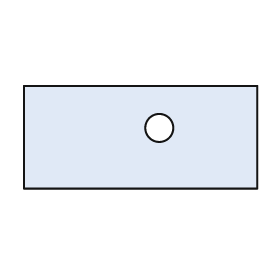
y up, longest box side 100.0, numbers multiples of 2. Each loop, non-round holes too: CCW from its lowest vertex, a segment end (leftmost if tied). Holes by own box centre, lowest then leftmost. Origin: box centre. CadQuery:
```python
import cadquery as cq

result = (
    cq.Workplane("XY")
    .moveTo(-50.0, -22.0)
    .lineTo(50.0, -22.0)
    .lineTo(50.0, 22.0)
    .lineTo(-50.0, 22.0)
    .close()
    .moveTo(8.0, 4.0)
    .circle(6.0)
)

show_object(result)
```